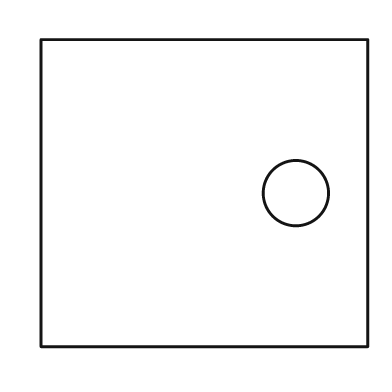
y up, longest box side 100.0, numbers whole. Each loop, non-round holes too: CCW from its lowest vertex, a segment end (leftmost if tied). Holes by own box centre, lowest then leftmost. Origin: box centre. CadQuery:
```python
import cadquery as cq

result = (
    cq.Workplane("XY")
    .moveTo(-50.0, -47.0)
    .lineTo(50.0, -47.0)
    .lineTo(50.0, 47.0)
    .lineTo(-50.0, 47.0)
    .close()
    .moveTo(28.0, 0.0)
    .circle(10.0)
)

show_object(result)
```